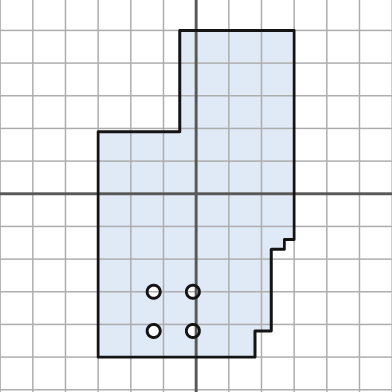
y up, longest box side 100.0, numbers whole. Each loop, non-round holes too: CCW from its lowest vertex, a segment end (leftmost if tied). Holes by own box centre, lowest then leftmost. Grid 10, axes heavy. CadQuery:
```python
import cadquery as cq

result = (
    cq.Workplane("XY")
    .moveTo(-30.0, -50.0)
    .lineTo(18.0, -50.0)
    .lineTo(18.0, -42.0)
    .lineTo(23.0, -42.0)
    .lineTo(23.0, -17.0)
    .lineTo(27.0, -17.0)
    .lineTo(27.0, -14.0)
    .lineTo(30.0, -14.0)
    .lineTo(30.0, 50.0)
    .lineTo(-5.0, 50.0)
    .lineTo(-5.0, 19.0)
    .lineTo(-30.0, 19.0)
    .close()
    .moveTo(-13.0, -42.0)
    .circle(2.0)
    .moveTo(-1.0, -42.0)
    .circle(2.0)
    .moveTo(-13.0, -30.0)
    .circle(2.0)
    .moveTo(-1.0, -30.0)
    .circle(2.0)
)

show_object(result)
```